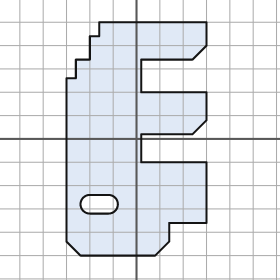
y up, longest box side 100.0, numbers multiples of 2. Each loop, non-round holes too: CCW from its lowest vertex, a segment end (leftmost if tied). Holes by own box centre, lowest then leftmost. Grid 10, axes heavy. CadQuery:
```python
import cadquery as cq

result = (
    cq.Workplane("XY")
    .moveTo(-24.0, -50.0)
    .lineTo(8.0, -50.0)
    .lineTo(14.0, -44.0)
    .lineTo(14.0, -36.0)
    .lineTo(30.0, -36.0)
    .lineTo(30.0, -10.0)
    .lineTo(2.0, -10.0)
    .lineTo(2.0, 2.0)
    .lineTo(24.0, 2.0)
    .lineTo(30.0, 8.0)
    .lineTo(30.0, 20.0)
    .lineTo(2.0, 20.0)
    .lineTo(2.0, 34.0)
    .lineTo(24.0, 34.0)
    .lineTo(30.0, 40.0)
    .lineTo(30.0, 50.0)
    .lineTo(-16.0, 50.0)
    .lineTo(-16.0, 44.0)
    .lineTo(-20.0, 44.0)
    .lineTo(-20.0, 34.0)
    .lineTo(-26.0, 34.0)
    .lineTo(-26.0, 26.0)
    .lineTo(-30.0, 26.0)
    .lineTo(-30.0, -44.0)
    .close()
    .moveTo(-20.0, -32.0)
    .lineTo(-12.0, -32.0)
    .threePointArc((-8.0, -28.0), (-12.0, -24.0))
    .lineTo(-20.0, -24.0)
    .threePointArc((-24.0, -28.0), (-20.0, -32.0))
    .close()
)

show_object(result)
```